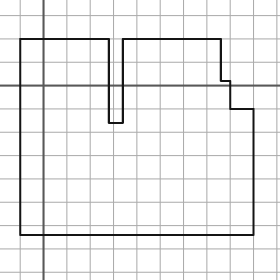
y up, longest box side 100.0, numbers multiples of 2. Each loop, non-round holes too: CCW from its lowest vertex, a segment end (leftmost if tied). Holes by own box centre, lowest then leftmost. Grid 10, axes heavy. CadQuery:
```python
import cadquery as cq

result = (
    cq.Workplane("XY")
    .moveTo(-10.0, -64.0)
    .lineTo(90.0, -64.0)
    .lineTo(90.0, -10.0)
    .lineTo(80.0, -10.0)
    .lineTo(80.0, 2.0)
    .lineTo(76.0, 2.0)
    .lineTo(76.0, 20.0)
    .lineTo(34.0, 20.0)
    .lineTo(34.0, -16.0)
    .lineTo(28.0, -16.0)
    .lineTo(28.0, 20.0)
    .lineTo(-10.0, 20.0)
    .close()
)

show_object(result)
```